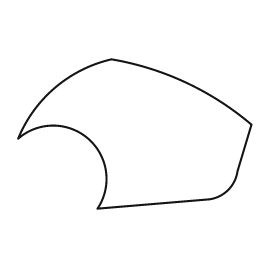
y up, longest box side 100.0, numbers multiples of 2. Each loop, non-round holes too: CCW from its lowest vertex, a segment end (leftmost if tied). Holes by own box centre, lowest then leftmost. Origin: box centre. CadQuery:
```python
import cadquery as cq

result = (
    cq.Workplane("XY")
    .moveTo(-16.0, -32.0)
    .lineTo(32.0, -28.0)
    .threePointArc((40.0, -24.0), (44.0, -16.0))
    .lineTo(50.0, 4.0)
    .threePointArc((22.0, 22.0), (-10.0, 32.0))
    .threePointArc((-34.0, 20.0), (-50.0, -2.0))
    .threePointArc((-20.0, -2.0), (-16.0, -32.0))
    .close()
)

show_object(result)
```